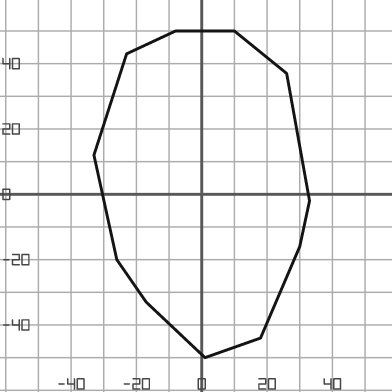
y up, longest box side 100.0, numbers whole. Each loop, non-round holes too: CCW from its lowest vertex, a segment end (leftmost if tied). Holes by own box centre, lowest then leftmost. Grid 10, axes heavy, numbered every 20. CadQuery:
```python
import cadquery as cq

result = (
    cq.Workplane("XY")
    .moveTo(1.0, -50.0)
    .lineTo(18.0, -44.0)
    .lineTo(30.0, -16.0)
    .lineTo(33.0, -2.0)
    .lineTo(26.0, 37.0)
    .lineTo(10.0, 50.0)
    .lineTo(-8.0, 50.0)
    .lineTo(-23.0, 43.0)
    .lineTo(-33.0, 12.0)
    .lineTo(-26.0, -20.0)
    .lineTo(-17.0, -33.0)
    .close()
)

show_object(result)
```